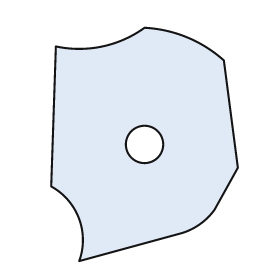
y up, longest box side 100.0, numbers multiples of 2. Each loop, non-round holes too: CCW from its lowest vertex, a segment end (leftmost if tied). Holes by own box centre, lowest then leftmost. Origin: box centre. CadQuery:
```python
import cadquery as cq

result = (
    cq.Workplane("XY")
    .moveTo(-28.0, -50.0)
    .lineTo(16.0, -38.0)
    .threePointArc((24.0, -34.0), (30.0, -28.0))
    .lineTo(40.0, -10.0)
    .lineTo(34.0, 36.0)
    .threePointArc((18.0, 46.0), (0.0, 50.0))
    .threePointArc((-18.0, 42.0), (-38.0, 42.0))
    .lineTo(-40.0, -18.0)
    .threePointArc((-28.0, -32.0), (-28.0, -50.0))
    .close()
    .moveTo(0.0, 0.0)
    .circle(8.0)
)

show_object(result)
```